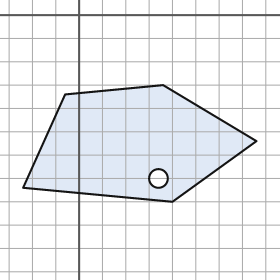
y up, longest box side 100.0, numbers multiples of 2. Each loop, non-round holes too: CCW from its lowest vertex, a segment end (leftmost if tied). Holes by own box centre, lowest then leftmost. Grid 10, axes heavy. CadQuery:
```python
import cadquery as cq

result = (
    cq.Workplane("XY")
    .moveTo(40.0, -80.0)
    .lineTo(76.0, -54.0)
    .lineTo(36.0, -30.0)
    .lineTo(-6.0, -34.0)
    .lineTo(-24.0, -74.0)
    .close()
    .moveTo(34.0, -70.0)
    .circle(4.0)
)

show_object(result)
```